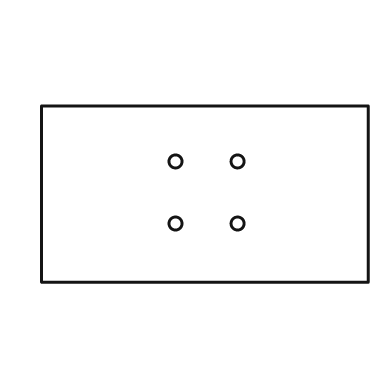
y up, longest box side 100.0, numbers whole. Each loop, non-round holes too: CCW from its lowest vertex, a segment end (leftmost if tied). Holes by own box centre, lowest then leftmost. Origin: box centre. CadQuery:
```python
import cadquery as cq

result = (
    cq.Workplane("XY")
    .moveTo(-50.0, -27.0)
    .lineTo(50.0, -27.0)
    .lineTo(50.0, 27.0)
    .lineTo(-50.0, 27.0)
    .close()
    .moveTo(-9.0, -9.0)
    .circle(2.0)
    .moveTo(10.0, -9.0)
    .circle(2.0)
    .moveTo(-9.0, 10.0)
    .circle(2.0)
    .moveTo(10.0, 10.0)
    .circle(2.0)
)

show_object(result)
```